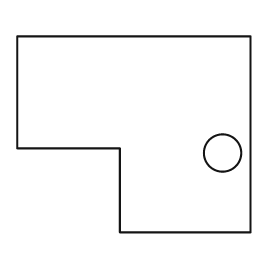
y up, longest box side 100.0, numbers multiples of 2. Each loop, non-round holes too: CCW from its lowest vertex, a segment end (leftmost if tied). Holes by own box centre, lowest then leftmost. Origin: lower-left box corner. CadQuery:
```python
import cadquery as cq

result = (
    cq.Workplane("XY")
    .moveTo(44.0, 0.0)
    .lineTo(100.0, 0.0)
    .lineTo(100.0, 84.0)
    .lineTo(0.0, 84.0)
    .lineTo(0.0, 36.0)
    .lineTo(44.0, 36.0)
    .close()
    .moveTo(88.0, 34.0)
    .circle(8.0)
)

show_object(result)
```